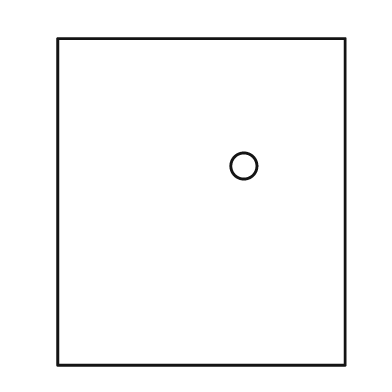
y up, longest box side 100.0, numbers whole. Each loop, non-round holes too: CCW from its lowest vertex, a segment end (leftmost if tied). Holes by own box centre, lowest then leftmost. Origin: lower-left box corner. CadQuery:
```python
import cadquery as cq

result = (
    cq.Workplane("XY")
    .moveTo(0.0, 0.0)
    .lineTo(88.0, 0.0)
    .lineTo(88.0, 100.0)
    .lineTo(0.0, 100.0)
    .close()
    .moveTo(57.0, 61.0)
    .circle(4.0)
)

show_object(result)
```